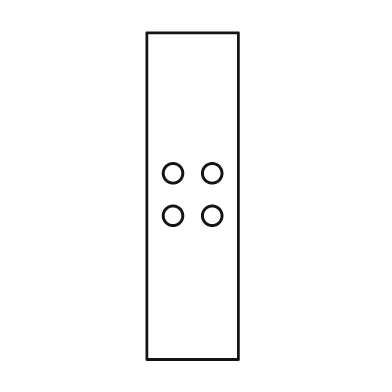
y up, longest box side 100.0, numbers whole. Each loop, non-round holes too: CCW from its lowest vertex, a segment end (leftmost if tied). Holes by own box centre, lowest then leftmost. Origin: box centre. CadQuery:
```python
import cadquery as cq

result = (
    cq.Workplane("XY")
    .moveTo(-14.0, -50.0)
    .lineTo(14.0, -50.0)
    .lineTo(14.0, 50.0)
    .lineTo(-14.0, 50.0)
    .close()
    .moveTo(-6.0, -6.0)
    .circle(3.0)
    .moveTo(6.0, -6.0)
    .circle(3.0)
    .moveTo(-6.0, 7.0)
    .circle(3.0)
    .moveTo(6.0, 7.0)
    .circle(3.0)
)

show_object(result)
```